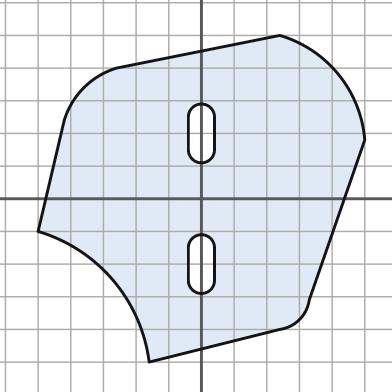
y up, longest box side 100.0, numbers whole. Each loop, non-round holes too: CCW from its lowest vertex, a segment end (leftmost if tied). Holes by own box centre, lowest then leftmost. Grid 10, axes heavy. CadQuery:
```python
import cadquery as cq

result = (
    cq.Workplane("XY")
    .moveTo(-16.0, -50.0)
    .lineTo(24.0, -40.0)
    .threePointArc((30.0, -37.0), (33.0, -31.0))
    .lineTo(50.0, 18.0)
    .threePointArc((42.0, 38.0), (24.0, 50.0))
    .lineTo(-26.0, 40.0)
    .threePointArc((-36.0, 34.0), (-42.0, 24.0))
    .lineTo(-50.0, -10.0)
    .threePointArc((-27.0, -25.0), (-16.0, -50.0))
    .close()
    .moveTo(-4.0, -25.0)
    .threePointArc((0.0, -29.0), (4.0, -25.0))
    .lineTo(4.0, -15.0)
    .threePointArc((0.0, -11.0), (-4.0, -15.0))
    .close()
    .moveTo(-4.0, 15.0)
    .threePointArc((0.0, 11.0), (4.0, 15.0))
    .lineTo(4.0, 25.0)
    .threePointArc((0.0, 29.0), (-4.0, 25.0))
    .close()
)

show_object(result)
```